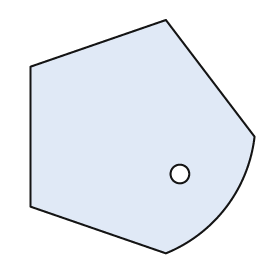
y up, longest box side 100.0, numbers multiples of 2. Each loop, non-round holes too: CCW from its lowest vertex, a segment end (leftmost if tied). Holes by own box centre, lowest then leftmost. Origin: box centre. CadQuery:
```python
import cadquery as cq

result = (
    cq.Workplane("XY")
    .moveTo(10.0, -50.0)
    .threePointArc((36.0, -30.0), (48.0, 0.0))
    .lineTo(10.0, 50.0)
    .lineTo(-48.0, 30.0)
    .lineTo(-48.0, -30.0)
    .close()
    .moveTo(16.0, -16.0)
    .circle(4.0)
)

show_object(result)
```